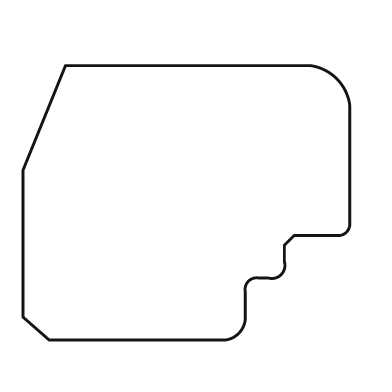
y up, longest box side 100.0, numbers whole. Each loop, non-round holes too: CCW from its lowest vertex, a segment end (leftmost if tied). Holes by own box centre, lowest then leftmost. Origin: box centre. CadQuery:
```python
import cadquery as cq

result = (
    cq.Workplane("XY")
    .moveTo(-42.0, -42.0)
    .lineTo(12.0, -42.0)
    .threePointArc((16.0, -40.0), (18.0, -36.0))
    .lineTo(18.0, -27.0)
    .threePointArc((19.0, -24.0), (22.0, -23.0))
    .lineTo(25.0, -23.0)
    .threePointArc((29.0, -22.0), (30.0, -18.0))
    .lineTo(30.0, -13.0)
    .lineTo(33.0, -10.0)
    .lineTo(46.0, -10.0)
    .threePointArc((49.0, -9.0), (50.0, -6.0))
    .lineTo(50.0, 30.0)
    .threePointArc((46.0, 38.0), (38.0, 42.0))
    .lineTo(-37.0, 42.0)
    .lineTo(-50.0, 10.0)
    .lineTo(-50.0, -35.0)
    .close()
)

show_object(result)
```